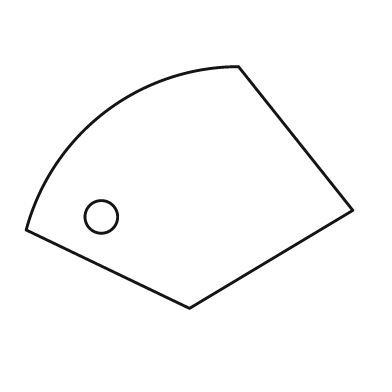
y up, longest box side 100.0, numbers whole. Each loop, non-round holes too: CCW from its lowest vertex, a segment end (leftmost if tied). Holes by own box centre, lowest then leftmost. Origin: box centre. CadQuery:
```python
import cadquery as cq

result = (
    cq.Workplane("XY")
    .moveTo(0.0, -37.0)
    .lineTo(50.0, -7.0)
    .lineTo(15.0, 37.0)
    .threePointArc((-26.0, 23.0), (-50.0, -13.0))
    .close()
    .moveTo(-27.0, -9.0)
    .circle(5.0)
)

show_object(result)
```